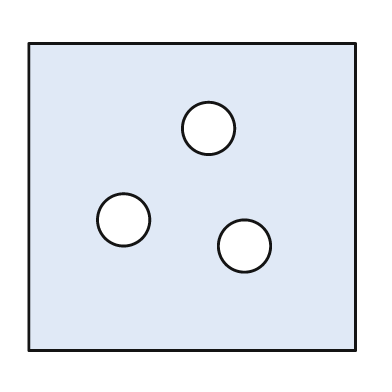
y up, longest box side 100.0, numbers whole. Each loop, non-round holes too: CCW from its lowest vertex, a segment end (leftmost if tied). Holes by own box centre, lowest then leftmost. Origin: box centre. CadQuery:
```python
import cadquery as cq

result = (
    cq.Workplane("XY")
    .moveTo(-50.0, -47.0)
    .lineTo(50.0, -47.0)
    .lineTo(50.0, 47.0)
    .lineTo(-50.0, 47.0)
    .close()
    .moveTo(16.0, -15.0)
    .circle(8.0)
    .moveTo(-21.0, -7.0)
    .circle(8.0)
    .moveTo(5.0, 21.0)
    .circle(8.0)
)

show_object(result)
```